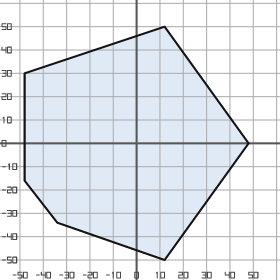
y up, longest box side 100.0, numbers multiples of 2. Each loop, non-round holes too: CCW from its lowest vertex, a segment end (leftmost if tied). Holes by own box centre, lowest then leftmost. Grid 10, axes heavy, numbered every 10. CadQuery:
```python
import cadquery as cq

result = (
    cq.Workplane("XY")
    .moveTo(12.0, -50.0)
    .lineTo(48.0, 0.0)
    .lineTo(12.0, 50.0)
    .lineTo(-48.0, 30.0)
    .lineTo(-48.0, -16.0)
    .lineTo(-34.0, -34.0)
    .close()
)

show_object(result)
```